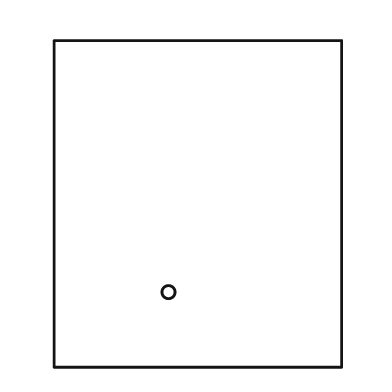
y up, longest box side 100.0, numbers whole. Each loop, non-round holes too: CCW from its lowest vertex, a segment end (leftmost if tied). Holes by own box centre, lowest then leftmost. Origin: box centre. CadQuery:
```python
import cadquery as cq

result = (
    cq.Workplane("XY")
    .moveTo(-44.0, -50.0)
    .lineTo(44.0, -50.0)
    .lineTo(44.0, 50.0)
    .lineTo(-44.0, 50.0)
    .close()
    .moveTo(-9.0, -27.0)
    .circle(2.0)
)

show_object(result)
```